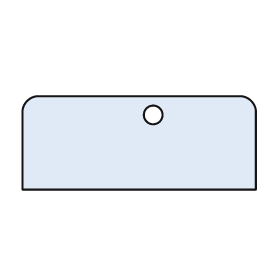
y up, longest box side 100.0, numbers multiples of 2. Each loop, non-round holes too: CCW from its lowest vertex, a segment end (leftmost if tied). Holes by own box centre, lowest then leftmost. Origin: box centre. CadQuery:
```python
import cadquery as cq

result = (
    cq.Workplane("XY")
    .moveTo(-50.0, -20.0)
    .lineTo(50.0, -20.0)
    .lineTo(50.0, 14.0)
    .threePointArc((48.0, 18.0), (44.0, 20.0))
    .lineTo(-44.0, 20.0)
    .threePointArc((-48.0, 18.0), (-50.0, 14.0))
    .close()
    .moveTo(6.0, 12.0)
    .circle(4.0)
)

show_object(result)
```